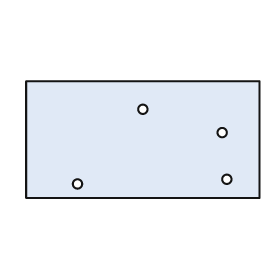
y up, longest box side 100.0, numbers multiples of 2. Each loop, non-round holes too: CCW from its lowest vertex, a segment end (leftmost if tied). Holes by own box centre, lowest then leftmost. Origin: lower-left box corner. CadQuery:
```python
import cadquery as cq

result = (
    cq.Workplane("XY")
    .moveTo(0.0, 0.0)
    .lineTo(100.0, 0.0)
    .lineTo(100.0, 50.0)
    .lineTo(0.0, 50.0)
    .close()
    .moveTo(22.0, 6.0)
    .circle(2.0)
    .moveTo(86.0, 8.0)
    .circle(2.0)
    .moveTo(84.0, 28.0)
    .circle(2.0)
    .moveTo(50.0, 38.0)
    .circle(2.0)
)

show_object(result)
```